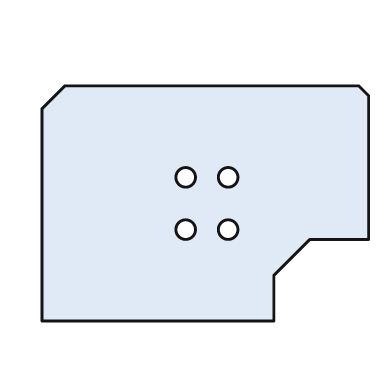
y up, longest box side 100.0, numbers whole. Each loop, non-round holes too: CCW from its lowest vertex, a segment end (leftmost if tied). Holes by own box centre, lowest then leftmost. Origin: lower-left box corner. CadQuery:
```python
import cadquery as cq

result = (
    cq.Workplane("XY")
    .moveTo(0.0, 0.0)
    .lineTo(71.0, 0.0)
    .lineTo(71.0, 14.0)
    .lineTo(82.0, 25.0)
    .lineTo(100.0, 25.0)
    .lineTo(100.0, 69.0)
    .lineTo(97.0, 72.0)
    .lineTo(7.0, 72.0)
    .lineTo(0.0, 65.0)
    .close()
    .moveTo(44.0, 28.0)
    .circle(3.0)
    .moveTo(57.0, 28.0)
    .circle(3.0)
    .moveTo(44.0, 44.0)
    .circle(3.0)
    .moveTo(57.0, 44.0)
    .circle(3.0)
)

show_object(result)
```